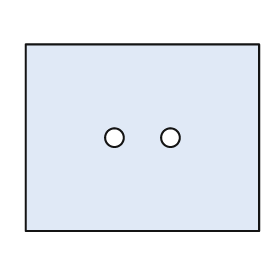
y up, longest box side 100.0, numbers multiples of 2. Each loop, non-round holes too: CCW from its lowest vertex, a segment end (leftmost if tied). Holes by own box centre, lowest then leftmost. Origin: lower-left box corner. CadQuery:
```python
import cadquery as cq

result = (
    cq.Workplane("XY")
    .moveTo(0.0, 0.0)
    .lineTo(100.0, 0.0)
    .lineTo(100.0, 80.0)
    .lineTo(0.0, 80.0)
    .close()
    .moveTo(38.0, 40.0)
    .circle(4.0)
    .moveTo(62.0, 40.0)
    .circle(4.0)
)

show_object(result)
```